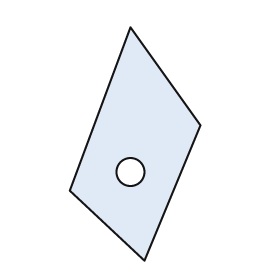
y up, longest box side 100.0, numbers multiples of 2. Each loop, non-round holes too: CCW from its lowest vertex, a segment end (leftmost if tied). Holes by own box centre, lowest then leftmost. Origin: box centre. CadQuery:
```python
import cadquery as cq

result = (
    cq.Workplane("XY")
    .moveTo(4.0, -50.0)
    .lineTo(28.0, 8.0)
    .lineTo(-2.0, 50.0)
    .lineTo(-28.0, -20.0)
    .close()
    .moveTo(-2.0, -12.0)
    .circle(6.0)
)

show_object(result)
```